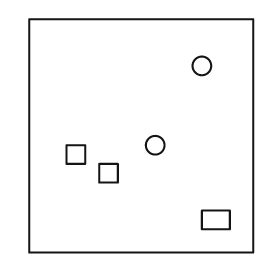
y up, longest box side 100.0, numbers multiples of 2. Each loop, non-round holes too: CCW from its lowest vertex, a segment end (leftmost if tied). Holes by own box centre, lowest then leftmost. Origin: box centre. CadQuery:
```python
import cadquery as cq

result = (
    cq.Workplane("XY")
    .moveTo(-48.0, -50.0)
    .lineTo(48.0, -50.0)
    .lineTo(48.0, 50.0)
    .lineTo(-48.0, 50.0)
    .close()
    .moveTo(26.0, -40.0)
    .lineTo(38.0, -40.0)
    .lineTo(38.0, -32.0)
    .lineTo(26.0, -32.0)
    .close()
    .moveTo(-18.0, -20.0)
    .lineTo(-10.0, -20.0)
    .lineTo(-10.0, -12.0)
    .lineTo(-18.0, -12.0)
    .close()
    .moveTo(-32.0, -12.0)
    .lineTo(-24.0, -12.0)
    .lineTo(-24.0, -4.0)
    .lineTo(-32.0, -4.0)
    .close()
    .moveTo(6.0, -4.0)
    .circle(4.0)
    .moveTo(26.0, 30.0)
    .circle(4.0)
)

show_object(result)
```